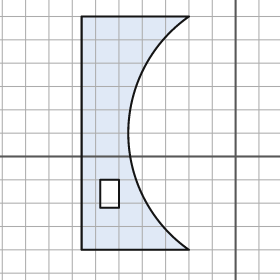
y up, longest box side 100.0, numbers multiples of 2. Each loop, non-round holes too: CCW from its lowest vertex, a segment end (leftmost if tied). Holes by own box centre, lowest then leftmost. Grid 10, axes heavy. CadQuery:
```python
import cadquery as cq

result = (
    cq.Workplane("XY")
    .moveTo(-66.0, -40.0)
    .lineTo(-20.0, -40.0)
    .threePointArc((-46.0, 10.0), (-20.0, 60.0))
    .lineTo(-66.0, 60.0)
    .close()
    .moveTo(-58.0, -22.0)
    .lineTo(-50.0, -22.0)
    .lineTo(-50.0, -10.0)
    .lineTo(-58.0, -10.0)
    .close()
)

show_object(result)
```